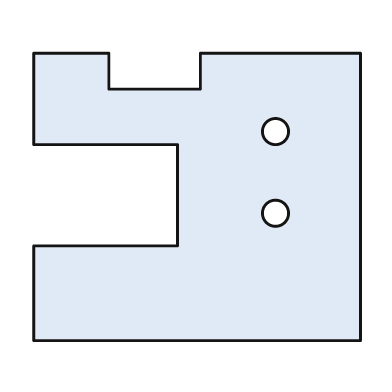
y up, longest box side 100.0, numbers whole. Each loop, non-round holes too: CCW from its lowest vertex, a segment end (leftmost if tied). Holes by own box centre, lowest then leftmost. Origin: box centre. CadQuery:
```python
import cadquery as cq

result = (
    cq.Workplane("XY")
    .moveTo(-50.0, -44.0)
    .lineTo(50.0, -44.0)
    .lineTo(50.0, 44.0)
    .lineTo(1.0, 44.0)
    .lineTo(1.0, 33.0)
    .lineTo(-27.0, 33.0)
    .lineTo(-27.0, 44.0)
    .lineTo(-50.0, 44.0)
    .lineTo(-50.0, 16.0)
    .lineTo(-6.0, 16.0)
    .lineTo(-6.0, -15.0)
    .lineTo(-50.0, -15.0)
    .close()
    .moveTo(24.0, -5.0)
    .circle(4.0)
    .moveTo(24.0, 20.0)
    .circle(4.0)
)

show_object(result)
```